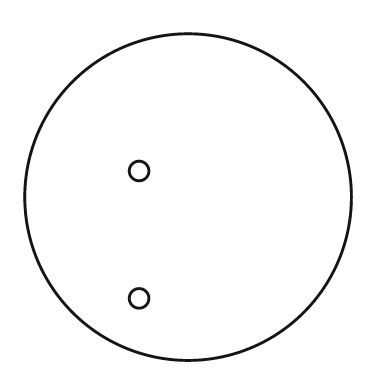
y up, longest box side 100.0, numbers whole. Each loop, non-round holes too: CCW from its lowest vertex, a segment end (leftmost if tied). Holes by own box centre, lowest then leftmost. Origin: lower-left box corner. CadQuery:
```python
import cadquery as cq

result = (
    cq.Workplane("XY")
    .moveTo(50.0, 50.0)
    .circle(50.0)
    .moveTo(35.0, 19.0)
    .circle(3.0)
    .moveTo(35.0, 58.0)
    .circle(3.0)
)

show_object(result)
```